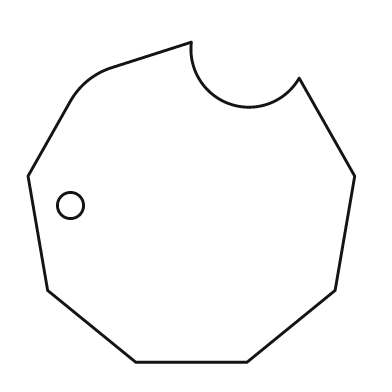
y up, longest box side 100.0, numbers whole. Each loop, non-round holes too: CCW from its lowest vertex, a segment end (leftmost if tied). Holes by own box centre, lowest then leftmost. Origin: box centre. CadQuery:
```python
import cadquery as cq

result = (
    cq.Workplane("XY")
    .moveTo(-17.0, -49.0)
    .lineTo(17.0, -49.0)
    .lineTo(44.0, -27.0)
    .lineTo(50.0, 8.0)
    .lineTo(33.0, 38.0)
    .threePointArc((12.0, 30.0), (0.0, 49.0))
    .lineTo(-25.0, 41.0)
    .threePointArc((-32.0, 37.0), (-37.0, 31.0))
    .lineTo(-50.0, 8.0)
    .lineTo(-44.0, -27.0)
    .close()
    .moveTo(-37.0, -1.0)
    .circle(4.0)
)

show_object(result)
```